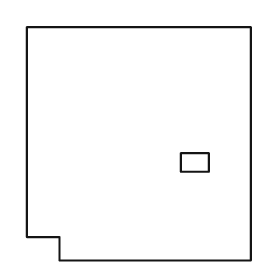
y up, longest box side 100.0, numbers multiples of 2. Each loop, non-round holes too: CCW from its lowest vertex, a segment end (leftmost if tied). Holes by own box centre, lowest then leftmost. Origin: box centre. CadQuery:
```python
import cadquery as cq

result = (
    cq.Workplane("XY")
    .moveTo(-34.0, -50.0)
    .lineTo(48.0, -50.0)
    .lineTo(48.0, 50.0)
    .lineTo(-48.0, 50.0)
    .lineTo(-48.0, -40.0)
    .lineTo(-34.0, -40.0)
    .close()
    .moveTo(18.0, -12.0)
    .lineTo(30.0, -12.0)
    .lineTo(30.0, -4.0)
    .lineTo(18.0, -4.0)
    .close()
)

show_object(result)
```